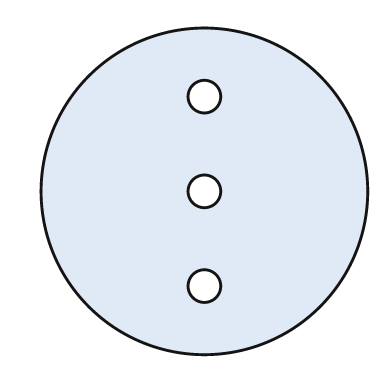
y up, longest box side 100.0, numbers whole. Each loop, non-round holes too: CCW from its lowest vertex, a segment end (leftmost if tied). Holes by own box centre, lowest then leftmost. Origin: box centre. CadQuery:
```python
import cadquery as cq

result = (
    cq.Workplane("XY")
    .moveTo(0.0, 0.0)
    .circle(50.0)
    .moveTo(0.0, -29.0)
    .circle(5.0)
    .moveTo(0.0, 0.0)
    .circle(5.0)
    .moveTo(0.0, 29.0)
    .circle(5.0)
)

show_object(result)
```